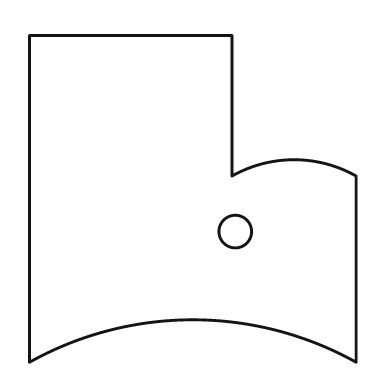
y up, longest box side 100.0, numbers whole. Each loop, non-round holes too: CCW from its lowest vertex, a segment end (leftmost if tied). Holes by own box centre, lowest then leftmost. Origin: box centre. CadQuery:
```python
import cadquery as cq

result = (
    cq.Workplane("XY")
    .moveTo(-50.0, -50.0)
    .threePointArc((0.0, -37.0), (50.0, -50.0))
    .lineTo(50.0, 7.0)
    .threePointArc((31.0, 12.0), (12.0, 7.0))
    .lineTo(12.0, 50.0)
    .lineTo(-50.0, 50.0)
    .close()
    .moveTo(13.0, -10.0)
    .circle(5.0)
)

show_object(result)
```